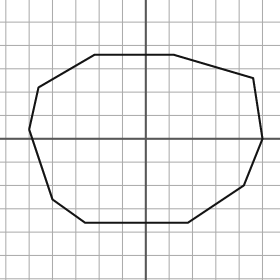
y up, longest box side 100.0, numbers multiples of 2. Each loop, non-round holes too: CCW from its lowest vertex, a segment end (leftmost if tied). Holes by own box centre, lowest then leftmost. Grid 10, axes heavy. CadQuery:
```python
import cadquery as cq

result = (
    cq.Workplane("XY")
    .moveTo(-26.0, -36.0)
    .lineTo(18.0, -36.0)
    .lineTo(42.0, -20.0)
    .lineTo(50.0, 0.0)
    .lineTo(46.0, 26.0)
    .lineTo(12.0, 36.0)
    .lineTo(-22.0, 36.0)
    .lineTo(-46.0, 22.0)
    .lineTo(-50.0, 4.0)
    .lineTo(-40.0, -26.0)
    .close()
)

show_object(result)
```